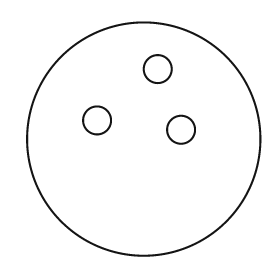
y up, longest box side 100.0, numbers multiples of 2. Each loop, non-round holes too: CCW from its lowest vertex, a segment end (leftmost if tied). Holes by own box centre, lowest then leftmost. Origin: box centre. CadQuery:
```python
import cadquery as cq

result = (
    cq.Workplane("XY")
    .moveTo(0.0, 0.0)
    .circle(50.0)
    .moveTo(16.0, 4.0)
    .circle(6.0)
    .moveTo(-20.0, 8.0)
    .circle(6.0)
    .moveTo(6.0, 30.0)
    .circle(6.0)
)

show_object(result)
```